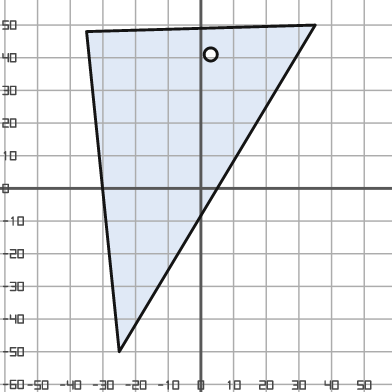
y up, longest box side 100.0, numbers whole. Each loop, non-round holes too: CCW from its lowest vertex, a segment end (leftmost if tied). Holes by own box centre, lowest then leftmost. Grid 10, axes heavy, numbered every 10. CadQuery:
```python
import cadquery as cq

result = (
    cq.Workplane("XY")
    .moveTo(-25.0, -50.0)
    .lineTo(35.0, 50.0)
    .lineTo(-35.0, 48.0)
    .close()
    .moveTo(3.0, 41.0)
    .circle(2.0)
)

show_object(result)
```